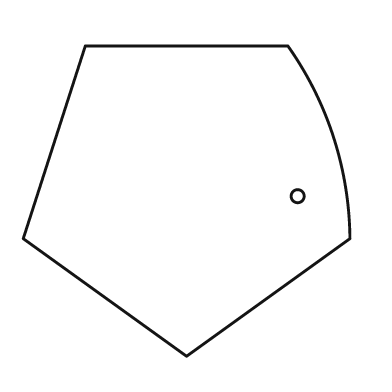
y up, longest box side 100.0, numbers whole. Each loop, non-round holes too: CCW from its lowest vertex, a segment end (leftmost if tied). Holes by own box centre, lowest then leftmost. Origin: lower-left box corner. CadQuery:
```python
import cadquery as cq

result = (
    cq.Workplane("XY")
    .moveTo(50.0, 0.0)
    .lineTo(100.0, 36.0)
    .threePointArc((95.0, 67.0), (81.0, 95.0))
    .lineTo(19.0, 95.0)
    .lineTo(0.0, 36.0)
    .close()
    .moveTo(84.0, 49.0)
    .circle(2.0)
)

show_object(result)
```